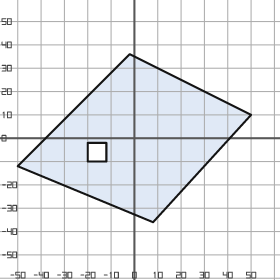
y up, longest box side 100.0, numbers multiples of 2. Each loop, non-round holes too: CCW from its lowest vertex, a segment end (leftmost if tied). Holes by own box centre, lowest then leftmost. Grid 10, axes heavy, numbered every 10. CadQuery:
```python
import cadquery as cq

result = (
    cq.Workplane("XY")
    .moveTo(8.0, -36.0)
    .lineTo(50.0, 10.0)
    .lineTo(-2.0, 36.0)
    .lineTo(-50.0, -12.0)
    .close()
    .moveTo(-20.0, -10.0)
    .lineTo(-12.0, -10.0)
    .lineTo(-12.0, -2.0)
    .lineTo(-20.0, -2.0)
    .close()
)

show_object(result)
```